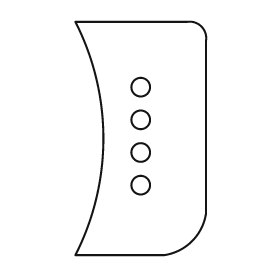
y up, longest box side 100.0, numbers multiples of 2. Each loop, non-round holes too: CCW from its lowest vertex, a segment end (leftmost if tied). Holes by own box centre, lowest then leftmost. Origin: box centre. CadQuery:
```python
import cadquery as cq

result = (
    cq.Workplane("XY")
    .moveTo(-28.0, -50.0)
    .lineTo(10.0, -50.0)
    .threePointArc((22.0, -44.0), (28.0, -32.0))
    .lineTo(28.0, 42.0)
    .threePointArc((26.0, 48.0), (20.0, 50.0))
    .lineTo(-28.0, 50.0)
    .threePointArc((-16.0, 0.0), (-28.0, -50.0))
    .close()
    .moveTo(0.0, -20.0)
    .circle(4.0)
    .moveTo(0.0, -6.0)
    .circle(4.0)
    .moveTo(0.0, 8.0)
    .circle(4.0)
    .moveTo(0.0, 22.0)
    .circle(4.0)
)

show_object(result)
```